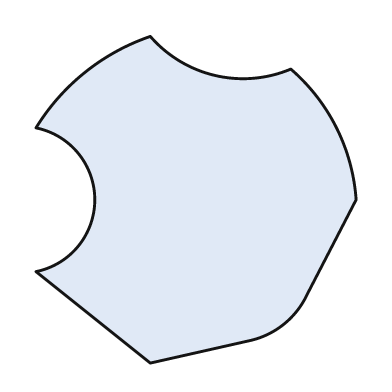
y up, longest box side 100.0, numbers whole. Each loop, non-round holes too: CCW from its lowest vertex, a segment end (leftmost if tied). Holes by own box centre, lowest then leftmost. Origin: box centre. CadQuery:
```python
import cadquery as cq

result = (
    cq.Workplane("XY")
    .moveTo(-14.0, -50.0)
    .lineTo(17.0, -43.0)
    .threePointArc((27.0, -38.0), (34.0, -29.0))
    .lineTo(49.0, 0.0)
    .threePointArc((43.0, 22.0), (29.0, 40.0))
    .threePointArc((6.0, 38.0), (-14.0, 50.0))
    .threePointArc((-34.0, 39.0), (-49.0, 22.0))
    .threePointArc((-31.0, 0.0), (-49.0, -22.0))
    .close()
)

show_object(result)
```